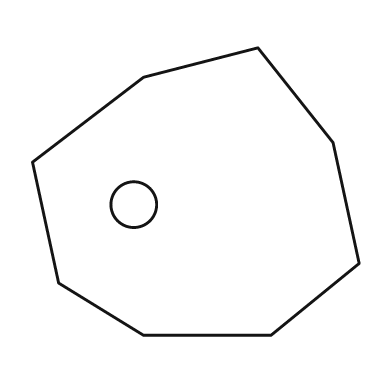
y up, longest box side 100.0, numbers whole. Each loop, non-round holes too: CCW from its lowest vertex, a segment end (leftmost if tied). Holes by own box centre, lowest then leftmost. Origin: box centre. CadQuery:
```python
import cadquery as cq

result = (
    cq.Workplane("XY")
    .moveTo(-16.0, -44.0)
    .lineTo(23.0, -44.0)
    .lineTo(50.0, -22.0)
    .lineTo(42.0, 15.0)
    .lineTo(19.0, 44.0)
    .lineTo(-16.0, 35.0)
    .lineTo(-50.0, 9.0)
    .lineTo(-42.0, -28.0)
    .close()
    .moveTo(-19.0, -4.0)
    .circle(7.0)
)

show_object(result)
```